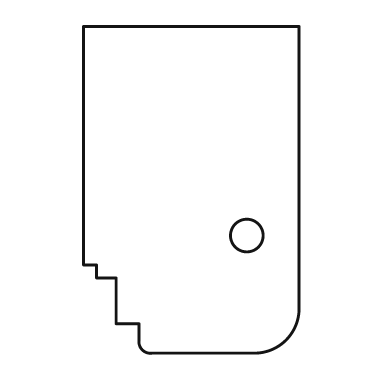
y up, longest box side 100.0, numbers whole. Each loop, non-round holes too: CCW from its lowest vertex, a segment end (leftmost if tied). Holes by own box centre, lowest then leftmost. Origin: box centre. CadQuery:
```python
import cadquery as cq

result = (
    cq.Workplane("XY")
    .moveTo(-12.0, -50.0)
    .lineTo(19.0, -50.0)
    .threePointArc((29.0, -46.0), (33.0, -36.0))
    .lineTo(33.0, 50.0)
    .lineTo(-33.0, 50.0)
    .lineTo(-33.0, -23.0)
    .lineTo(-29.0, -23.0)
    .lineTo(-29.0, -27.0)
    .lineTo(-23.0, -27.0)
    .lineTo(-23.0, -41.0)
    .lineTo(-16.0, -41.0)
    .lineTo(-16.0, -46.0)
    .threePointArc((-15.0, -49.0), (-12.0, -50.0))
    .close()
    .moveTo(17.0, -14.0)
    .circle(5.0)
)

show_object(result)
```